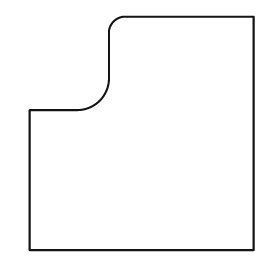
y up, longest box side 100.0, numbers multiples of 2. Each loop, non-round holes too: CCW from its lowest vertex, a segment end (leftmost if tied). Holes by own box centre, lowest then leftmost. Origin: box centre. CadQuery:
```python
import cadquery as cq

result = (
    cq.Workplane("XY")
    .moveTo(-48.0, -50.0)
    .lineTo(48.0, -50.0)
    .lineTo(48.0, 50.0)
    .lineTo(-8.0, 50.0)
    .threePointArc((-12.0, 48.0), (-14.0, 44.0))
    .lineTo(-14.0, 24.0)
    .threePointArc((-18.0, 14.0), (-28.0, 10.0))
    .lineTo(-48.0, 10.0)
    .close()
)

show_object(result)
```